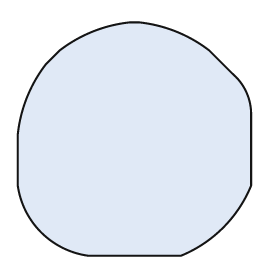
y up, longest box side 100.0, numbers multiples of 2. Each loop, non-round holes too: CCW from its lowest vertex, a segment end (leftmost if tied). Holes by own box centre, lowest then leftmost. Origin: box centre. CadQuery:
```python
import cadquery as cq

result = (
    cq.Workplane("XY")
    .moveTo(-20.0, -50.0)
    .lineTo(20.0, -50.0)
    .threePointArc((38.0, -38.0), (50.0, -20.0))
    .lineTo(50.0, 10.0)
    .threePointArc((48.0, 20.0), (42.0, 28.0))
    .lineTo(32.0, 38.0)
    .threePointArc((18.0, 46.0), (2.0, 50.0))
    .lineTo(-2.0, 50.0)
    .threePointArc((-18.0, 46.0), (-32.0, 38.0))
    .lineTo(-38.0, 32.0)
    .threePointArc((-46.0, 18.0), (-50.0, 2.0))
    .lineTo(-50.0, -20.0)
    .threePointArc((-40.0, -40.0), (-20.0, -50.0))
    .close()
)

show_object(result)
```